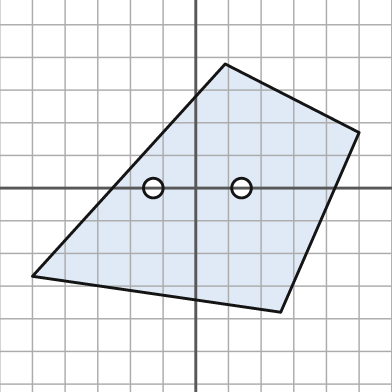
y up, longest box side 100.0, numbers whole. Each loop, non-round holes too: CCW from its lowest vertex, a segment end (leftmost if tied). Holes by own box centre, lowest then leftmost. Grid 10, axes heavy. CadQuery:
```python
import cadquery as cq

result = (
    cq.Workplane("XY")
    .moveTo(26.0, -38.0)
    .lineTo(50.0, 17.0)
    .lineTo(9.0, 38.0)
    .lineTo(-50.0, -27.0)
    .close()
    .moveTo(-13.0, 0.0)
    .circle(3.0)
    .moveTo(14.0, 0.0)
    .circle(3.0)
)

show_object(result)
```